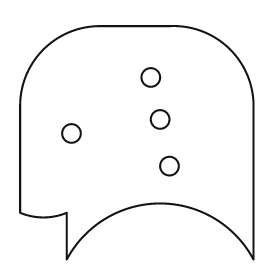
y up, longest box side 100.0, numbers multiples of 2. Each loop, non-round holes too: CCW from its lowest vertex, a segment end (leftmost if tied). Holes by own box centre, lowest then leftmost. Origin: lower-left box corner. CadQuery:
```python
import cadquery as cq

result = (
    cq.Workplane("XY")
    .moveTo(20.0, 0.0)
    .threePointArc((60.0, 24.0), (100.0, 0.0))
    .lineTo(100.0, 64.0)
    .threePointArc((90.0, 90.0), (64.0, 100.0))
    .lineTo(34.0, 100.0)
    .threePointArc((10.0, 90.0), (0.0, 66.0))
    .lineTo(0.0, 20.0)
    .threePointArc((10.0, 18.0), (20.0, 20.0))
    .close()
    .moveTo(64.0, 40.0)
    .circle(4.0)
    .moveTo(22.0, 54.0)
    .circle(4.0)
    .moveTo(60.0, 60.0)
    .circle(4.0)
    .moveTo(56.0, 78.0)
    .circle(4.0)
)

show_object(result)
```